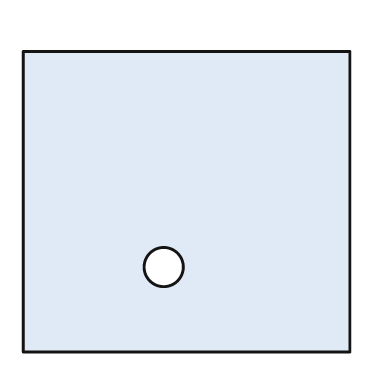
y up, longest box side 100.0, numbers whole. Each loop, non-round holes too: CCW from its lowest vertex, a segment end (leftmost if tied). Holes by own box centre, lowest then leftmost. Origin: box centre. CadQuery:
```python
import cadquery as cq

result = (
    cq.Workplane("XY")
    .moveTo(-50.0, -46.0)
    .lineTo(50.0, -46.0)
    .lineTo(50.0, 46.0)
    .lineTo(-50.0, 46.0)
    .close()
    .moveTo(-7.0, -20.0)
    .circle(6.0)
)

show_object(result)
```